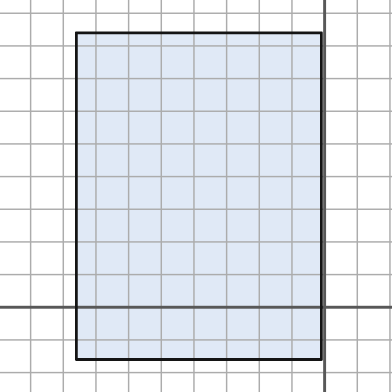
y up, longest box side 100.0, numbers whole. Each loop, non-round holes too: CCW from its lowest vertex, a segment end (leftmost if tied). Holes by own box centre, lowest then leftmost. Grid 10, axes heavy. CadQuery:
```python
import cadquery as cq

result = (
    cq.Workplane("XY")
    .moveTo(-76.0, -16.0)
    .lineTo(-1.0, -16.0)
    .lineTo(-1.0, 84.0)
    .lineTo(-76.0, 84.0)
    .close()
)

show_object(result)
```